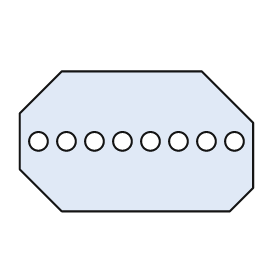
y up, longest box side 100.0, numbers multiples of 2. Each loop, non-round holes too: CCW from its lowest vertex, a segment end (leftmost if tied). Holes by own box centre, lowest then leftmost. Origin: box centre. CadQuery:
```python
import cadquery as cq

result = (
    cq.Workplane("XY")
    .moveTo(-32.0, -30.0)
    .lineTo(40.0, -30.0)
    .lineTo(50.0, -20.0)
    .lineTo(50.0, 8.0)
    .lineTo(28.0, 30.0)
    .lineTo(-32.0, 30.0)
    .lineTo(-50.0, 12.0)
    .lineTo(-50.0, -12.0)
    .close()
    .moveTo(-42.0, 0.0)
    .circle(4.0)
    .moveTo(-30.0, 0.0)
    .circle(4.0)
    .moveTo(-18.0, 0.0)
    .circle(4.0)
    .moveTo(-6.0, 0.0)
    .circle(4.0)
    .moveTo(6.0, 0.0)
    .circle(4.0)
    .moveTo(18.0, 0.0)
    .circle(4.0)
    .moveTo(30.0, 0.0)
    .circle(4.0)
    .moveTo(42.0, 0.0)
    .circle(4.0)
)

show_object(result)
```